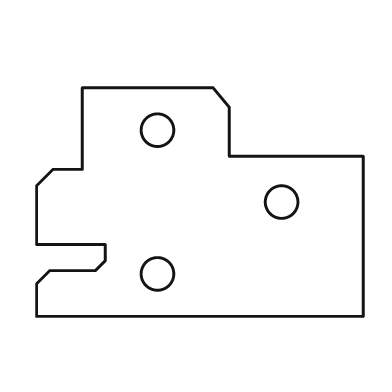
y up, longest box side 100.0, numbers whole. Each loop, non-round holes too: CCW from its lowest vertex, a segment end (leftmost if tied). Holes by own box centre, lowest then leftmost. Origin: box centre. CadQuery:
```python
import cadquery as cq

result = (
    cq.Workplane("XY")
    .moveTo(-50.0, -35.0)
    .lineTo(50.0, -35.0)
    .lineTo(50.0, 14.0)
    .lineTo(9.0, 14.0)
    .lineTo(9.0, 29.0)
    .lineTo(4.0, 35.0)
    .lineTo(-36.0, 35.0)
    .lineTo(-36.0, 10.0)
    .lineTo(-45.0, 10.0)
    .lineTo(-50.0, 5.0)
    .lineTo(-50.0, -13.0)
    .lineTo(-29.0, -13.0)
    .lineTo(-29.0, -18.0)
    .lineTo(-32.0, -21.0)
    .lineTo(-46.0, -21.0)
    .lineTo(-50.0, -25.0)
    .close()
    .moveTo(-13.0, -22.0)
    .circle(5.0)
    .moveTo(25.0, 0.0)
    .circle(5.0)
    .moveTo(-13.0, 22.0)
    .circle(5.0)
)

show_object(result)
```